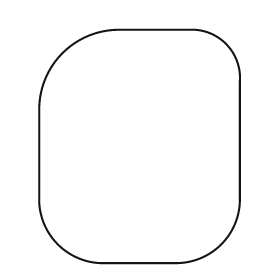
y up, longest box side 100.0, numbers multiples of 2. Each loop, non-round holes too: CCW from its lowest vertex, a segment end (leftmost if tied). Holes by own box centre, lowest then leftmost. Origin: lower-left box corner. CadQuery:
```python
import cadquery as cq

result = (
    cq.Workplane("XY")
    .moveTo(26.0, 0.0)
    .lineTo(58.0, 0.0)
    .threePointArc((78.0, 8.0), (86.0, 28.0))
    .lineTo(86.0, 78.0)
    .threePointArc((80.0, 94.0), (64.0, 100.0))
    .lineTo(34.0, 100.0)
    .threePointArc((10.0, 90.0), (0.0, 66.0))
    .lineTo(0.0, 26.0)
    .threePointArc((8.0, 8.0), (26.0, 0.0))
    .close()
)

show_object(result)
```